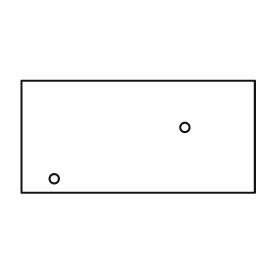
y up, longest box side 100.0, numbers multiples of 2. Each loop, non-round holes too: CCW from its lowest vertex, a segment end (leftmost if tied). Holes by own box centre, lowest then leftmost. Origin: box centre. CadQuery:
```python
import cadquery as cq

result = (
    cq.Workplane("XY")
    .moveTo(-50.0, -24.0)
    .lineTo(50.0, -24.0)
    .lineTo(50.0, 24.0)
    .lineTo(-50.0, 24.0)
    .close()
    .moveTo(-36.0, -18.0)
    .circle(2.0)
    .moveTo(20.0, 4.0)
    .circle(2.0)
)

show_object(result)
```